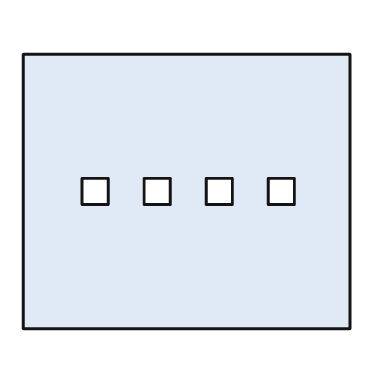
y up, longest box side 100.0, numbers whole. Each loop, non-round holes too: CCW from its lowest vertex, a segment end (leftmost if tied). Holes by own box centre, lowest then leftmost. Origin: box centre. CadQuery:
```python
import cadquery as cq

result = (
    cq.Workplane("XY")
    .moveTo(-50.0, -42.0)
    .lineTo(50.0, -42.0)
    .lineTo(50.0, 42.0)
    .lineTo(-50.0, 42.0)
    .close()
    .moveTo(-32.0, -4.0)
    .lineTo(-24.0, -4.0)
    .lineTo(-24.0, 4.0)
    .lineTo(-32.0, 4.0)
    .close()
    .moveTo(-13.0, -4.0)
    .lineTo(-5.0, -4.0)
    .lineTo(-5.0, 4.0)
    .lineTo(-13.0, 4.0)
    .close()
    .moveTo(6.0, -4.0)
    .lineTo(14.0, -4.0)
    .lineTo(14.0, 4.0)
    .lineTo(6.0, 4.0)
    .close()
    .moveTo(25.0, -4.0)
    .lineTo(33.0, -4.0)
    .lineTo(33.0, 4.0)
    .lineTo(25.0, 4.0)
    .close()
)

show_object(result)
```